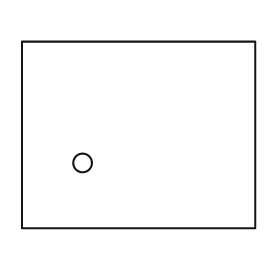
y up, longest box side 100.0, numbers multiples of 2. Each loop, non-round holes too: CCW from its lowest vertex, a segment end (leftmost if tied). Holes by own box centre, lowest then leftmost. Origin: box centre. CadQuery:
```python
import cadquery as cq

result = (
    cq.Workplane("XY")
    .moveTo(-50.0, -40.0)
    .lineTo(50.0, -40.0)
    .lineTo(50.0, 40.0)
    .lineTo(-50.0, 40.0)
    .close()
    .moveTo(-24.0, -12.0)
    .circle(4.0)
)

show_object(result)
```